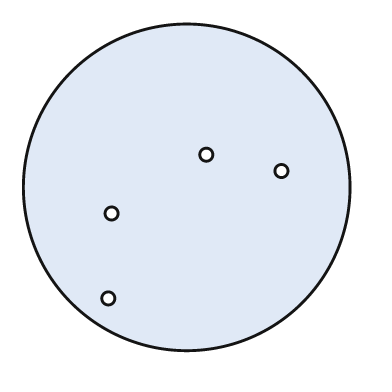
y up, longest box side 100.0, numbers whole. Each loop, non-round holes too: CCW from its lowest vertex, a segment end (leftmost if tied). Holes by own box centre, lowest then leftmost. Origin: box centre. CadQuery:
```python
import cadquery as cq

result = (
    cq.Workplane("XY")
    .moveTo(0.0, 0.0)
    .circle(50.0)
    .moveTo(-24.0, -34.0)
    .circle(2.0)
    .moveTo(-23.0, -8.0)
    .circle(2.0)
    .moveTo(29.0, 5.0)
    .circle(2.0)
    .moveTo(6.0, 10.0)
    .circle(2.0)
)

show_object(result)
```